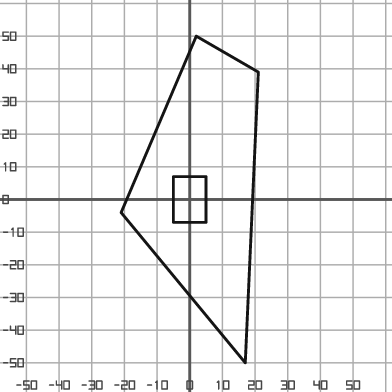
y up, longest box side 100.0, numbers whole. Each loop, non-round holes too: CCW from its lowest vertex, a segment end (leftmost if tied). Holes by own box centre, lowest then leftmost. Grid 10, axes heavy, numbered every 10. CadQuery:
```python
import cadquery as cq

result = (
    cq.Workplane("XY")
    .moveTo(17.0, -50.0)
    .lineTo(21.0, 39.0)
    .lineTo(2.0, 50.0)
    .lineTo(-21.0, -4.0)
    .close()
    .moveTo(-5.0, -7.0)
    .lineTo(5.0, -7.0)
    .lineTo(5.0, 7.0)
    .lineTo(-5.0, 7.0)
    .close()
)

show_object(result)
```